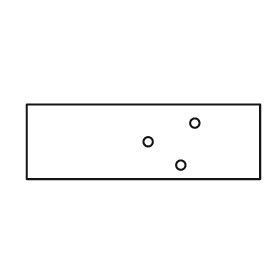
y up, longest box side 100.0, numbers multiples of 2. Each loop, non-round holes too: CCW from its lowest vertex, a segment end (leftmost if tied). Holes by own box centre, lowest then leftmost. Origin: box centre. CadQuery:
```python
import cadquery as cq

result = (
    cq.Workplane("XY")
    .moveTo(-50.0, -16.0)
    .lineTo(50.0, -16.0)
    .lineTo(50.0, 16.0)
    .lineTo(-50.0, 16.0)
    .close()
    .moveTo(16.0, -10.0)
    .circle(2.0)
    .moveTo(2.0, 0.0)
    .circle(2.0)
    .moveTo(22.0, 8.0)
    .circle(2.0)
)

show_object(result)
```